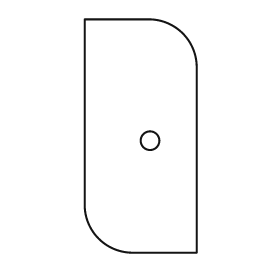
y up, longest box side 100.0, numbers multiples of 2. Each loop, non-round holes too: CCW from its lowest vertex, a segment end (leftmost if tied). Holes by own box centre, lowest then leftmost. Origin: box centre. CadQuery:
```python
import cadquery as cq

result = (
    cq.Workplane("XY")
    .moveTo(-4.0, -50.0)
    .lineTo(24.0, -50.0)
    .lineTo(24.0, 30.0)
    .threePointArc((18.0, 44.0), (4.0, 50.0))
    .lineTo(-24.0, 50.0)
    .lineTo(-24.0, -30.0)
    .threePointArc((-18.0, -44.0), (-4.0, -50.0))
    .close()
    .moveTo(4.0, -2.0)
    .circle(4.0)
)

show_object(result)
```